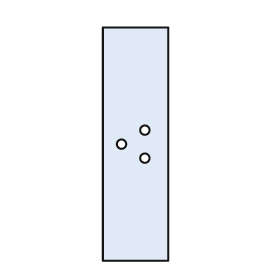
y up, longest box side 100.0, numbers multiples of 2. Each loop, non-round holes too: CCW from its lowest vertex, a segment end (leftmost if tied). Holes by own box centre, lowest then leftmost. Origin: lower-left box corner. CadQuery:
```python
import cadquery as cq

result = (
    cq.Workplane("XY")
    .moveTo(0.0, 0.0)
    .lineTo(28.0, 0.0)
    .lineTo(28.0, 100.0)
    .lineTo(0.0, 100.0)
    .close()
    .moveTo(18.0, 44.0)
    .circle(2.0)
    .moveTo(8.0, 50.0)
    .circle(2.0)
    .moveTo(18.0, 56.0)
    .circle(2.0)
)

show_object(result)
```